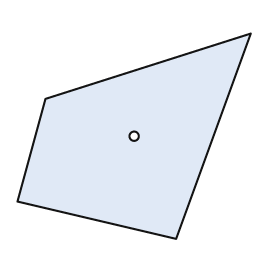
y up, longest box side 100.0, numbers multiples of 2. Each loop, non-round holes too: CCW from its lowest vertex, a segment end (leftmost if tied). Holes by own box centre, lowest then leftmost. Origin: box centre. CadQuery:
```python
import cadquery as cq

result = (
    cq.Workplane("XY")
    .moveTo(18.0, -44.0)
    .lineTo(50.0, 44.0)
    .lineTo(-38.0, 16.0)
    .lineTo(-50.0, -28.0)
    .close()
    .moveTo(0.0, 0.0)
    .circle(2.0)
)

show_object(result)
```